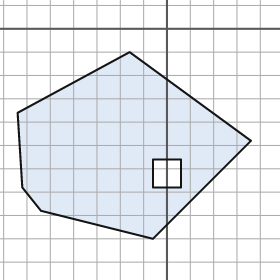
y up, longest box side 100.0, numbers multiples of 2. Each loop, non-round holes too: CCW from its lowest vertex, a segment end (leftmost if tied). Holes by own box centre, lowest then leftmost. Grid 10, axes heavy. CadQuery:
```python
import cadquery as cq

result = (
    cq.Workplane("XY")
    .moveTo(-6.0, -90.0)
    .lineTo(36.0, -48.0)
    .lineTo(-16.0, -10.0)
    .lineTo(-64.0, -36.0)
    .lineTo(-62.0, -68.0)
    .lineTo(-54.0, -78.0)
    .close()
    .moveTo(-6.0, -68.0)
    .lineTo(6.0, -68.0)
    .lineTo(6.0, -56.0)
    .lineTo(-6.0, -56.0)
    .close()
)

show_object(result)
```